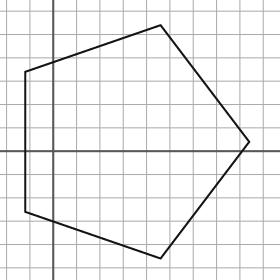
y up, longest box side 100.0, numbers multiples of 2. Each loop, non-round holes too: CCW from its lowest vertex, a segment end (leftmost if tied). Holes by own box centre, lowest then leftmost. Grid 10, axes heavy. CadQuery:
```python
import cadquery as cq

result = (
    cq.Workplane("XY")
    .moveTo(46.0, -46.0)
    .lineTo(84.0, 4.0)
    .lineTo(46.0, 54.0)
    .lineTo(-12.0, 34.0)
    .lineTo(-12.0, -26.0)
    .close()
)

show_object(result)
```